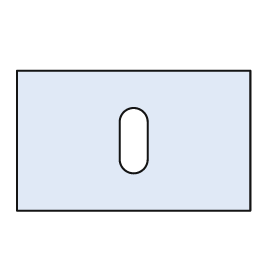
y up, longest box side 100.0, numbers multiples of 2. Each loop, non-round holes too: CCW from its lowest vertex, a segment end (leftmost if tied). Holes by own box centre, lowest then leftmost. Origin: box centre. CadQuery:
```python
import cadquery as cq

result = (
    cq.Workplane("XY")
    .moveTo(-50.0, -30.0)
    .lineTo(50.0, -30.0)
    .lineTo(50.0, 30.0)
    .lineTo(-50.0, 30.0)
    .close()
    .moveTo(-6.0, -8.0)
    .threePointArc((0.0, -14.0), (6.0, -8.0))
    .lineTo(6.0, 8.0)
    .threePointArc((0.0, 14.0), (-6.0, 8.0))
    .close()
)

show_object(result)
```